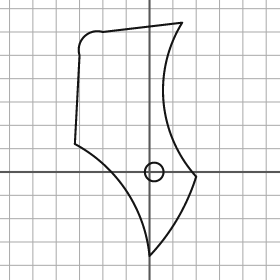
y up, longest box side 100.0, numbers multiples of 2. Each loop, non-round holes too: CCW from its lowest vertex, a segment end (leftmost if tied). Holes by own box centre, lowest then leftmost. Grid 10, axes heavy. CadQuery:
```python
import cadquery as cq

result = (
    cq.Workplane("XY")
    .moveTo(0.0, -36.0)
    .threePointArc((12.0, -20.0), (20.0, -2.0))
    .threePointArc((6.0, 30.0), (14.0, 64.0))
    .lineTo(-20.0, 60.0)
    .threePointArc((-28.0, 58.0), (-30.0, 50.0))
    .lineTo(-32.0, 12.0)
    .threePointArc((-10.0, -8.0), (0.0, -36.0))
    .close()
    .moveTo(2.0, 0.0)
    .circle(4.0)
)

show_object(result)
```